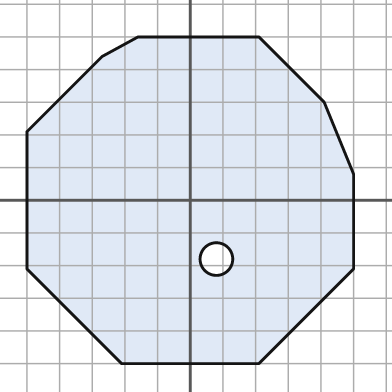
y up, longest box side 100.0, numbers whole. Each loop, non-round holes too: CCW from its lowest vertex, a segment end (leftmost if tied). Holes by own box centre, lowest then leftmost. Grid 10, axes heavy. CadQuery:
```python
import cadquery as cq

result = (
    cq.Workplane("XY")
    .moveTo(-21.0, -50.0)
    .lineTo(21.0, -50.0)
    .lineTo(50.0, -21.0)
    .lineTo(50.0, 8.0)
    .lineTo(41.0, 30.0)
    .lineTo(21.0, 50.0)
    .lineTo(-16.0, 50.0)
    .lineTo(-27.0, 44.0)
    .lineTo(-50.0, 21.0)
    .lineTo(-50.0, -21.0)
    .close()
    .moveTo(8.0, -18.0)
    .circle(5.0)
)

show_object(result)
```